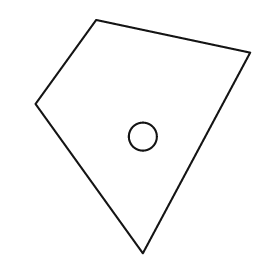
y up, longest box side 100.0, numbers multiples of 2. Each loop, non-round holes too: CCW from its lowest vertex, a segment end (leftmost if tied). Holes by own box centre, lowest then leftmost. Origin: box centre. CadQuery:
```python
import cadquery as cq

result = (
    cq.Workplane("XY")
    .moveTo(0.0, -50.0)
    .lineTo(46.0, 36.0)
    .lineTo(-20.0, 50.0)
    .lineTo(-46.0, 14.0)
    .close()
    .moveTo(0.0, 0.0)
    .circle(6.0)
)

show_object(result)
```